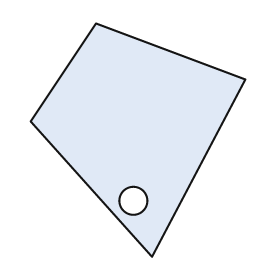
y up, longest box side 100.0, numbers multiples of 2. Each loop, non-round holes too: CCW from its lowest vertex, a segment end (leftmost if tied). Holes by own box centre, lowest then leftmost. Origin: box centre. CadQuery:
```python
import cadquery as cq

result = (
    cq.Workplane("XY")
    .moveTo(6.0, -50.0)
    .lineTo(46.0, 26.0)
    .lineTo(-18.0, 50.0)
    .lineTo(-46.0, 8.0)
    .close()
    .moveTo(-2.0, -26.0)
    .circle(6.0)
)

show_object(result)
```